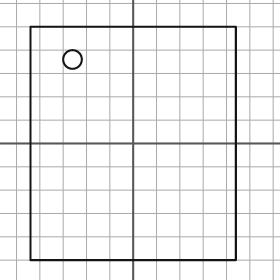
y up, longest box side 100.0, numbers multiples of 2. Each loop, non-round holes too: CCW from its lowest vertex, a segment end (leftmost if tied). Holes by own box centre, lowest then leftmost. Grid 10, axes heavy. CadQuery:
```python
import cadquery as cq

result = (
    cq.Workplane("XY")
    .moveTo(-44.0, -50.0)
    .lineTo(44.0, -50.0)
    .lineTo(44.0, 50.0)
    .lineTo(-44.0, 50.0)
    .close()
    .moveTo(-26.0, 36.0)
    .circle(4.0)
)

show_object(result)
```